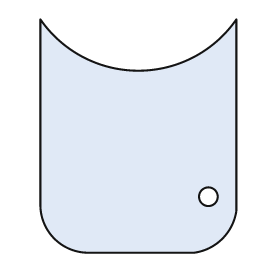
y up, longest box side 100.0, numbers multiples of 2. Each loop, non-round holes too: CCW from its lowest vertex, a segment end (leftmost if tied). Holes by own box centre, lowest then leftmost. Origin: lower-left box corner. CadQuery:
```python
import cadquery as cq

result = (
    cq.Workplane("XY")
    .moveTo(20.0, 0.0)
    .lineTo(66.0, 0.0)
    .threePointArc((78.0, 6.0), (84.0, 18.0))
    .lineTo(84.0, 100.0)
    .threePointArc((42.0, 78.0), (0.0, 100.0))
    .lineTo(0.0, 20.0)
    .threePointArc((6.0, 6.0), (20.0, 0.0))
    .close()
    .moveTo(72.0, 24.0)
    .circle(4.0)
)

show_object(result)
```